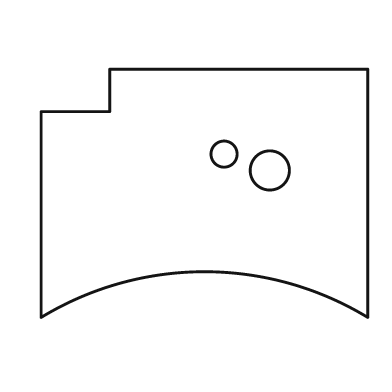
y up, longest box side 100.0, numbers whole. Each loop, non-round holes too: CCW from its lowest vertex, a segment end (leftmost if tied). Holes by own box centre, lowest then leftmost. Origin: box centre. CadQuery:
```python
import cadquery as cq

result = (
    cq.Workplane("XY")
    .moveTo(-50.0, -38.0)
    .threePointArc((0.0, -24.0), (50.0, -38.0))
    .lineTo(50.0, 38.0)
    .lineTo(-29.0, 38.0)
    .lineTo(-29.0, 25.0)
    .lineTo(-50.0, 25.0)
    .close()
    .moveTo(20.0, 7.0)
    .circle(6.0)
    .moveTo(6.0, 12.0)
    .circle(4.0)
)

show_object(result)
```